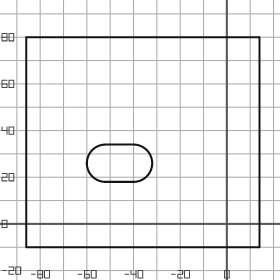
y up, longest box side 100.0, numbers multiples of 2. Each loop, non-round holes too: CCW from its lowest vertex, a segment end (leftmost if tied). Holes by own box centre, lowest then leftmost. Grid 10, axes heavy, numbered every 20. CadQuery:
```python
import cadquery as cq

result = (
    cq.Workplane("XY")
    .moveTo(-86.0, -10.0)
    .lineTo(14.0, -10.0)
    .lineTo(14.0, 80.0)
    .lineTo(-86.0, 80.0)
    .close()
    .moveTo(-52.0, 18.0)
    .lineTo(-40.0, 18.0)
    .threePointArc((-32.0, 26.0), (-40.0, 34.0))
    .lineTo(-52.0, 34.0)
    .threePointArc((-60.0, 26.0), (-52.0, 18.0))
    .close()
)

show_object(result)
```